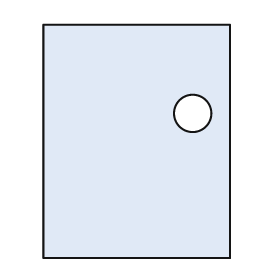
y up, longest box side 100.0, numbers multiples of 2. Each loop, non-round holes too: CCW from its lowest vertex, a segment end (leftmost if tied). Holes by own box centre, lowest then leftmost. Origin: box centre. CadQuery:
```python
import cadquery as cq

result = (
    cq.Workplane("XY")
    .moveTo(-40.0, -50.0)
    .lineTo(40.0, -50.0)
    .lineTo(40.0, 50.0)
    .lineTo(-40.0, 50.0)
    .close()
    .moveTo(24.0, 12.0)
    .circle(8.0)
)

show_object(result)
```